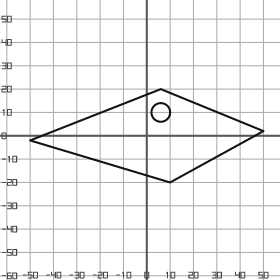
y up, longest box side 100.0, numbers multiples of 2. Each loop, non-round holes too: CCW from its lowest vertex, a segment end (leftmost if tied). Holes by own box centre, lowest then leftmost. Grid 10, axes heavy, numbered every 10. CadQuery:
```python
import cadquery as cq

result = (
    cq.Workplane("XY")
    .moveTo(10.0, -20.0)
    .lineTo(50.0, 2.0)
    .lineTo(6.0, 20.0)
    .lineTo(-50.0, -2.0)
    .close()
    .moveTo(6.0, 10.0)
    .circle(4.0)
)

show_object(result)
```